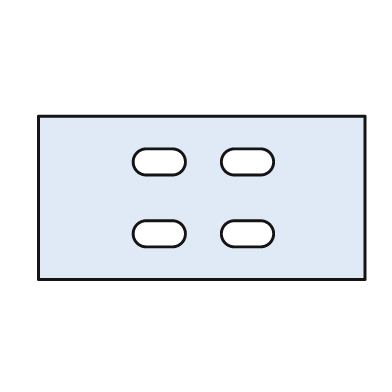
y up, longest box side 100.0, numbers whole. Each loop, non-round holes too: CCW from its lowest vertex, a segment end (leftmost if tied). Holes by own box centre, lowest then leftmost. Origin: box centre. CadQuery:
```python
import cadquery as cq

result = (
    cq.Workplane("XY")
    .moveTo(-50.0, -25.0)
    .lineTo(50.0, -25.0)
    .lineTo(50.0, 25.0)
    .lineTo(-50.0, 25.0)
    .close()
    .moveTo(-17.0, -15.0)
    .lineTo(-9.0, -15.0)
    .threePointArc((-5.0, -11.0), (-9.0, -7.0))
    .lineTo(-17.0, -7.0)
    .threePointArc((-21.0, -11.0), (-17.0, -15.0))
    .close()
    .moveTo(10.0, -15.0)
    .lineTo(18.0, -15.0)
    .threePointArc((22.0, -11.0), (18.0, -7.0))
    .lineTo(10.0, -7.0)
    .threePointArc((6.0, -11.0), (10.0, -15.0))
    .close()
    .moveTo(-17.0, 7.0)
    .lineTo(-9.0, 7.0)
    .threePointArc((-5.0, 11.0), (-9.0, 15.0))
    .lineTo(-17.0, 15.0)
    .threePointArc((-21.0, 11.0), (-17.0, 7.0))
    .close()
    .moveTo(10.0, 7.0)
    .lineTo(18.0, 7.0)
    .threePointArc((22.0, 11.0), (18.0, 15.0))
    .lineTo(10.0, 15.0)
    .threePointArc((6.0, 11.0), (10.0, 7.0))
    .close()
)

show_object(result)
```